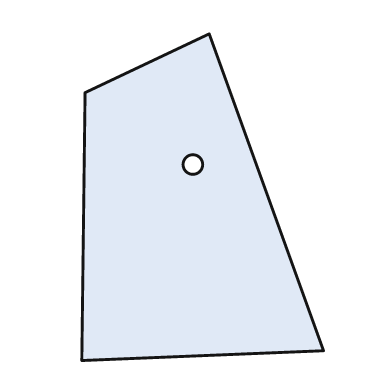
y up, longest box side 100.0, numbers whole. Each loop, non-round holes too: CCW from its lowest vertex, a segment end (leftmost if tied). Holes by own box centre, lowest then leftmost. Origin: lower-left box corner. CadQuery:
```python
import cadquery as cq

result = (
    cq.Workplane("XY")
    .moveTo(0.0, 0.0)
    .lineTo(74.0, 3.0)
    .lineTo(39.0, 100.0)
    .lineTo(1.0, 82.0)
    .close()
    .moveTo(34.0, 60.0)
    .circle(3.0)
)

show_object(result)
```